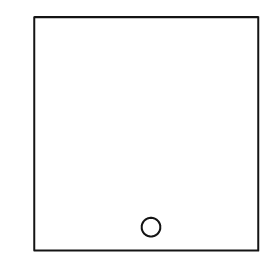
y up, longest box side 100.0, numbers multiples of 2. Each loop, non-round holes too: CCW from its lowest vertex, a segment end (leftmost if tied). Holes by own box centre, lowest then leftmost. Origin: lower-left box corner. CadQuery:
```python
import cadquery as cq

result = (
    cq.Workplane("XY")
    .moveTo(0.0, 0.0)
    .lineTo(96.0, 0.0)
    .lineTo(96.0, 100.0)
    .lineTo(0.0, 100.0)
    .close()
    .moveTo(50.0, 10.0)
    .circle(4.0)
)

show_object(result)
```